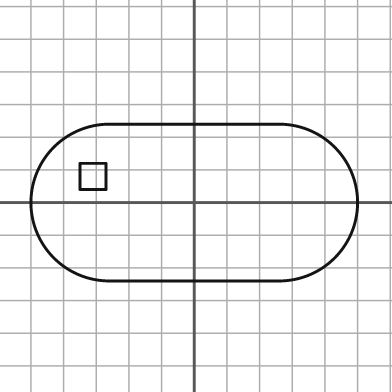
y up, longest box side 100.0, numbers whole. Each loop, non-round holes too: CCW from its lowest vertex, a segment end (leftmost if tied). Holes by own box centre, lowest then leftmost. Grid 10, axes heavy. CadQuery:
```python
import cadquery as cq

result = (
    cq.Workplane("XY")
    .moveTo(-26.0, -24.0)
    .lineTo(26.0, -24.0)
    .threePointArc((50.0, 0.0), (26.0, 24.0))
    .lineTo(-26.0, 24.0)
    .threePointArc((-50.0, 0.0), (-26.0, -24.0))
    .close()
    .moveTo(-35.0, 4.0)
    .lineTo(-27.0, 4.0)
    .lineTo(-27.0, 12.0)
    .lineTo(-35.0, 12.0)
    .close()
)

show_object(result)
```